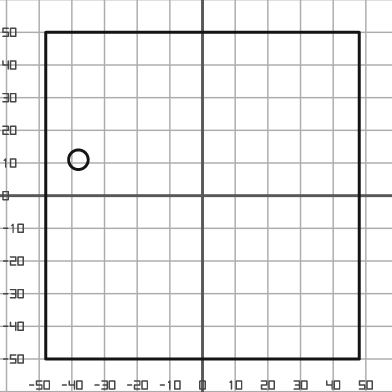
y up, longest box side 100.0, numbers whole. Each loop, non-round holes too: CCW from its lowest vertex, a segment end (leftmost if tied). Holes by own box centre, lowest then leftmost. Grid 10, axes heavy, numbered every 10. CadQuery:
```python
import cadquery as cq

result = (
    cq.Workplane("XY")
    .moveTo(-48.0, -50.0)
    .lineTo(48.0, -50.0)
    .lineTo(48.0, 50.0)
    .lineTo(-48.0, 50.0)
    .close()
    .moveTo(-38.0, 11.0)
    .circle(3.0)
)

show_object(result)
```